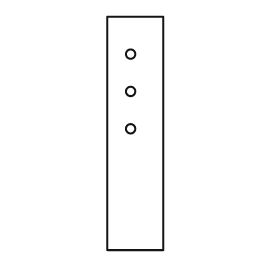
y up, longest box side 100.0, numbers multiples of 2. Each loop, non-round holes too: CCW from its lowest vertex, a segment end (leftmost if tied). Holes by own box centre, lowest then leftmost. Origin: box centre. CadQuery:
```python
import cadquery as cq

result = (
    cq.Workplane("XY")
    .moveTo(-12.0, -50.0)
    .lineTo(12.0, -50.0)
    .lineTo(12.0, 50.0)
    .lineTo(-12.0, 50.0)
    .close()
    .moveTo(-2.0, 2.0)
    .circle(2.0)
    .moveTo(-2.0, 18.0)
    .circle(2.0)
    .moveTo(-2.0, 34.0)
    .circle(2.0)
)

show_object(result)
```